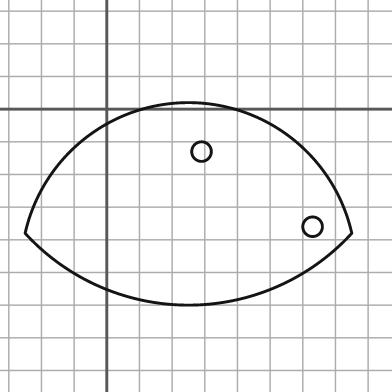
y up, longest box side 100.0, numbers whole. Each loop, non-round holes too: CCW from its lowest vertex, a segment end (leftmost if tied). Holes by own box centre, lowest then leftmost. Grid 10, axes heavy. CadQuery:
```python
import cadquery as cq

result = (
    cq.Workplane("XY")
    .moveTo(-25.0, -38.0)
    .threePointArc((25.0, -60.0), (75.0, -38.0))
    .threePointArc((25.0, 2.0), (-25.0, -38.0))
    .close()
    .moveTo(63.0, -36.0)
    .circle(3.0)
    .moveTo(29.0, -13.0)
    .circle(3.0)
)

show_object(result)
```